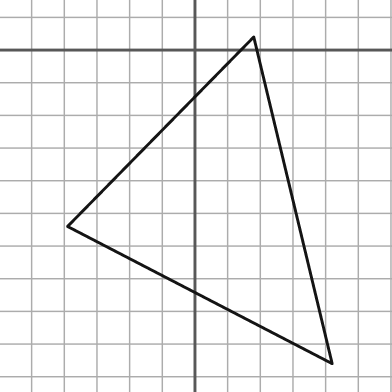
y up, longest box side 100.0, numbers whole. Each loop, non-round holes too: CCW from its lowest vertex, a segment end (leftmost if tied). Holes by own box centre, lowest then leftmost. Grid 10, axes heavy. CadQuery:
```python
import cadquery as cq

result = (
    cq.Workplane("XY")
    .moveTo(42.0, -96.0)
    .lineTo(18.0, 4.0)
    .lineTo(-39.0, -54.0)
    .close()
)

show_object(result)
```